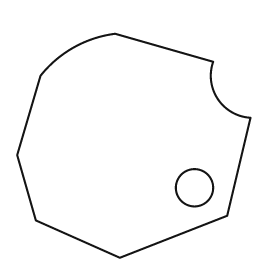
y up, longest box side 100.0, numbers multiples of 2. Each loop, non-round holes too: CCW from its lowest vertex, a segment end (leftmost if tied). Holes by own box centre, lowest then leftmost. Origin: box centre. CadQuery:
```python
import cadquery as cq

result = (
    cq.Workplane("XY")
    .moveTo(-6.0, -48.0)
    .lineTo(40.0, -30.0)
    .lineTo(50.0, 12.0)
    .threePointArc((36.0, 20.0), (34.0, 36.0))
    .lineTo(-8.0, 48.0)
    .threePointArc((-26.0, 42.0), (-40.0, 30.0))
    .lineTo(-50.0, -4.0)
    .lineTo(-42.0, -32.0)
    .close()
    .moveTo(26.0, -18.0)
    .circle(8.0)
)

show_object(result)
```